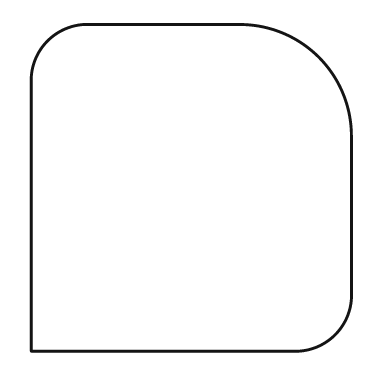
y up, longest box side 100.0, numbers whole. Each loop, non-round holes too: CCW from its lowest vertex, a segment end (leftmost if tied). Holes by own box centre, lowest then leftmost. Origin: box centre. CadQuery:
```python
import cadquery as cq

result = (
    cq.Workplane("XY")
    .moveTo(-49.0, -50.0)
    .lineTo(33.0, -50.0)
    .threePointArc((44.0, -45.0), (49.0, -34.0))
    .lineTo(49.0, 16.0)
    .threePointArc((39.0, 40.0), (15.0, 50.0))
    .lineTo(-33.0, 50.0)
    .threePointArc((-44.0, 45.0), (-49.0, 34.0))
    .close()
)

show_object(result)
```